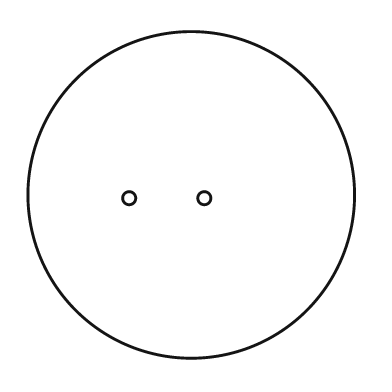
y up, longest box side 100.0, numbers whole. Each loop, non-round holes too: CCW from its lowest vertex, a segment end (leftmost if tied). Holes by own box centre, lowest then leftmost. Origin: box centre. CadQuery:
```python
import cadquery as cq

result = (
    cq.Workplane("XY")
    .moveTo(0.0, 0.0)
    .circle(50.0)
    .moveTo(-19.0, -1.0)
    .circle(2.0)
    .moveTo(4.0, -1.0)
    .circle(2.0)
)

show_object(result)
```